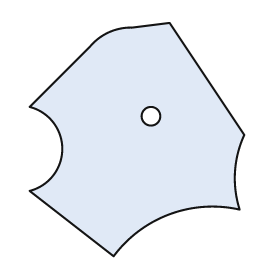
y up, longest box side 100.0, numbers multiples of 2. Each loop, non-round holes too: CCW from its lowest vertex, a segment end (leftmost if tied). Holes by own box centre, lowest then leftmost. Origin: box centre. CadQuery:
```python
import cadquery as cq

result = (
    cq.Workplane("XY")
    .moveTo(-10.0, -50.0)
    .threePointArc((14.0, -32.0), (44.0, -30.0))
    .threePointArc((42.0, -14.0), (46.0, 2.0))
    .lineTo(14.0, 50.0)
    .lineTo(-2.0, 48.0)
    .threePointArc((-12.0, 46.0), (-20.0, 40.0))
    .lineTo(-46.0, 14.0)
    .threePointArc((-32.0, -4.0), (-46.0, -22.0))
    .close()
    .moveTo(6.0, 10.0)
    .circle(4.0)
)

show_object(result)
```